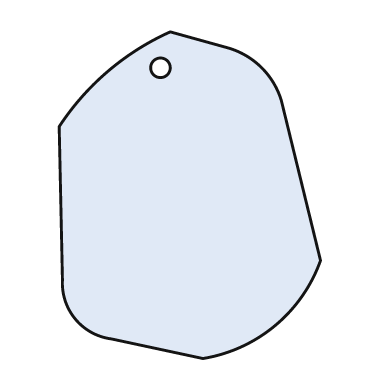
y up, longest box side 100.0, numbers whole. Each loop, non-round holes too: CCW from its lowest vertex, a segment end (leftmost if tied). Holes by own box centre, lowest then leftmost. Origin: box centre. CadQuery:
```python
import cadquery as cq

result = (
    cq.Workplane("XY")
    .moveTo(4.0, -50.0)
    .threePointArc((26.0, -40.0), (40.0, -20.0))
    .lineTo(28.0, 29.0)
    .threePointArc((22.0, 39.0), (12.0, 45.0))
    .lineTo(-6.0, 50.0)
    .threePointArc((-25.0, 38.0), (-40.0, 21.0))
    .lineTo(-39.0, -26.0)
    .threePointArc((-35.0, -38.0), (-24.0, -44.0))
    .close()
    .moveTo(-9.0, 39.0)
    .circle(3.0)
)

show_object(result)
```